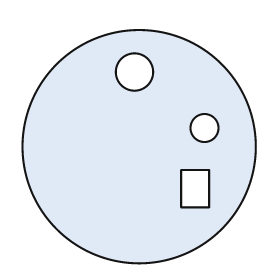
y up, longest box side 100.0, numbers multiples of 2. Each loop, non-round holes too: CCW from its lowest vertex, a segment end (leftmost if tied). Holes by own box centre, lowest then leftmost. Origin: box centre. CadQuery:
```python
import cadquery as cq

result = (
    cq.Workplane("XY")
    .moveTo(0.0, 0.0)
    .circle(50.0)
    .moveTo(18.0, -26.0)
    .lineTo(30.0, -26.0)
    .lineTo(30.0, -10.0)
    .lineTo(18.0, -10.0)
    .close()
    .moveTo(28.0, 8.0)
    .circle(6.0)
    .moveTo(-2.0, 32.0)
    .circle(8.0)
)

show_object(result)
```